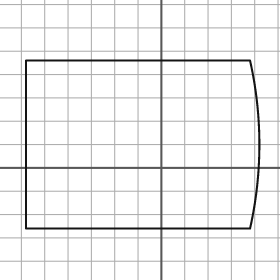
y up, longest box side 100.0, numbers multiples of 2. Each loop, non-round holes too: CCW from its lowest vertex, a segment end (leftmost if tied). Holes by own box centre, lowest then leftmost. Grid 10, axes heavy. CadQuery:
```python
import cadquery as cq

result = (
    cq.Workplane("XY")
    .moveTo(-58.0, -26.0)
    .lineTo(38.0, -26.0)
    .threePointArc((42.0, 10.0), (38.0, 46.0))
    .lineTo(-58.0, 46.0)
    .close()
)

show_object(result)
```